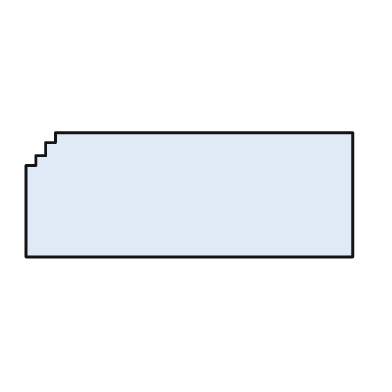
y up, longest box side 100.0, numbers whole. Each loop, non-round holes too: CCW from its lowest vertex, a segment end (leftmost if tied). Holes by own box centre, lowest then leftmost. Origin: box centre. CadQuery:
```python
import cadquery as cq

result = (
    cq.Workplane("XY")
    .moveTo(-50.0, -19.0)
    .lineTo(50.0, -19.0)
    .lineTo(50.0, 19.0)
    .lineTo(-41.0, 19.0)
    .lineTo(-41.0, 16.0)
    .lineTo(-44.0, 16.0)
    .lineTo(-44.0, 12.0)
    .lineTo(-47.0, 12.0)
    .lineTo(-47.0, 9.0)
    .lineTo(-50.0, 9.0)
    .close()
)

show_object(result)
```